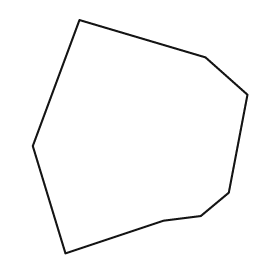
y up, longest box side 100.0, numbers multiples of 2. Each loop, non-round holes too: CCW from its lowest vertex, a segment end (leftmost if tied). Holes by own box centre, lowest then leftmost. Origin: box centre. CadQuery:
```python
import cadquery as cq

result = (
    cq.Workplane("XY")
    .moveTo(-32.0, -50.0)
    .lineTo(10.0, -36.0)
    .lineTo(26.0, -34.0)
    .lineTo(38.0, -24.0)
    .lineTo(46.0, 18.0)
    .lineTo(28.0, 34.0)
    .lineTo(-26.0, 50.0)
    .lineTo(-46.0, -4.0)
    .close()
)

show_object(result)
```